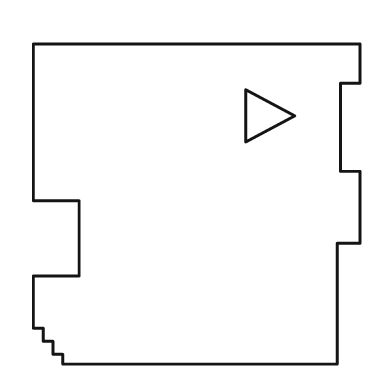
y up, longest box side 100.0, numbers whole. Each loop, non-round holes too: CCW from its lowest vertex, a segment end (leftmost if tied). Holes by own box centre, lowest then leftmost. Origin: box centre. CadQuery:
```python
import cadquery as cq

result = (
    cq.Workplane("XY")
    .moveTo(-41.0, -49.0)
    .lineTo(43.0, -49.0)
    .lineTo(43.0, -12.0)
    .lineTo(50.0, -12.0)
    .lineTo(50.0, 10.0)
    .lineTo(44.0, 10.0)
    .lineTo(44.0, 37.0)
    .lineTo(50.0, 37.0)
    .lineTo(50.0, 49.0)
    .lineTo(-50.0, 49.0)
    .lineTo(-50.0, 1.0)
    .lineTo(-36.0, 1.0)
    .lineTo(-36.0, -22.0)
    .lineTo(-50.0, -22.0)
    .lineTo(-50.0, -38.0)
    .lineTo(-47.0, -38.0)
    .lineTo(-47.0, -42.0)
    .lineTo(-44.0, -42.0)
    .lineTo(-44.0, -46.0)
    .lineTo(-41.0, -46.0)
    .close()
    .moveTo(15.0, 19.0)
    .lineTo(30.0, 27.0)
    .lineTo(15.0, 35.0)
    .close()
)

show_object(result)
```